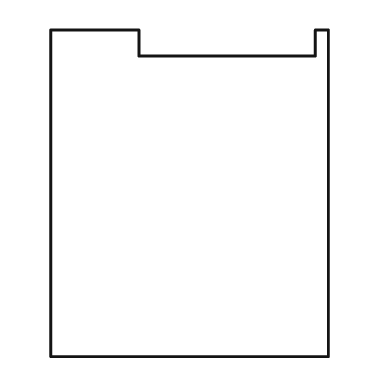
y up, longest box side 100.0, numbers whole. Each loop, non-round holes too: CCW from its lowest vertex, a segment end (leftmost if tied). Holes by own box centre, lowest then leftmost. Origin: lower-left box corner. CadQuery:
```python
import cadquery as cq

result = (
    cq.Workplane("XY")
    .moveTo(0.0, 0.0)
    .lineTo(85.0, 0.0)
    .lineTo(85.0, 100.0)
    .lineTo(81.0, 100.0)
    .lineTo(81.0, 92.0)
    .lineTo(27.0, 92.0)
    .lineTo(27.0, 100.0)
    .lineTo(0.0, 100.0)
    .close()
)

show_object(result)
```